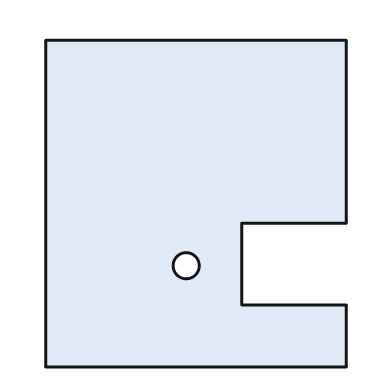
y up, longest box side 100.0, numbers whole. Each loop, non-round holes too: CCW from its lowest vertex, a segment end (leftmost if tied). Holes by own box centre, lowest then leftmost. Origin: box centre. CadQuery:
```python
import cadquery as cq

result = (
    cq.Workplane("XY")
    .moveTo(-46.0, -50.0)
    .lineTo(46.0, -50.0)
    .lineTo(46.0, -31.0)
    .lineTo(14.0, -31.0)
    .lineTo(14.0, -6.0)
    .lineTo(46.0, -6.0)
    .lineTo(46.0, 50.0)
    .lineTo(-46.0, 50.0)
    .close()
    .moveTo(-3.0, -19.0)
    .circle(4.0)
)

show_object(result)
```